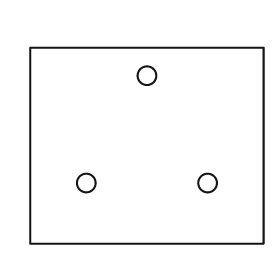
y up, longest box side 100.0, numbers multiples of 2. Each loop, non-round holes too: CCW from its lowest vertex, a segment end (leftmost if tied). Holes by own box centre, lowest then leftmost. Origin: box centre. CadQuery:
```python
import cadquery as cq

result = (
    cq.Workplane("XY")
    .moveTo(-50.0, -42.0)
    .lineTo(50.0, -42.0)
    .lineTo(50.0, 42.0)
    .lineTo(-50.0, 42.0)
    .close()
    .moveTo(-26.0, -16.0)
    .circle(4.0)
    .moveTo(26.0, -16.0)
    .circle(4.0)
    .moveTo(0.0, 30.0)
    .circle(4.0)
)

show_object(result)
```